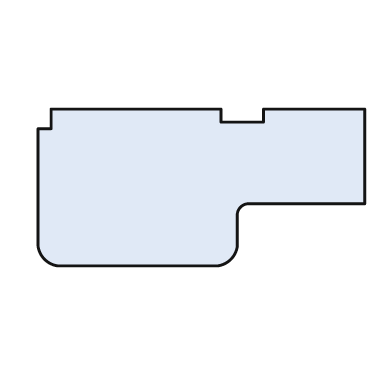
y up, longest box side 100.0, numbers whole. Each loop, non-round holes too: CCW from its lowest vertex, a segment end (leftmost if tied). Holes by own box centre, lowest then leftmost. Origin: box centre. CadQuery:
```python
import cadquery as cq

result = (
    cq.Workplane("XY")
    .moveTo(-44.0, -24.0)
    .lineTo(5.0, -24.0)
    .threePointArc((9.0, -22.0), (11.0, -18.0))
    .lineTo(11.0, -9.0)
    .threePointArc((12.0, -6.0), (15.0, -5.0))
    .lineTo(50.0, -5.0)
    .lineTo(50.0, 24.0)
    .lineTo(19.0, 24.0)
    .lineTo(19.0, 20.0)
    .lineTo(6.0, 20.0)
    .lineTo(6.0, 24.0)
    .lineTo(-46.0, 24.0)
    .lineTo(-46.0, 18.0)
    .lineTo(-50.0, 18.0)
    .lineTo(-50.0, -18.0)
    .threePointArc((-48.0, -22.0), (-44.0, -24.0))
    .close()
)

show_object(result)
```